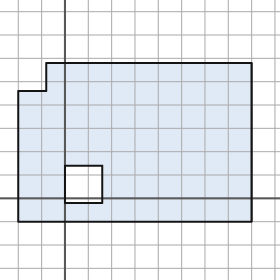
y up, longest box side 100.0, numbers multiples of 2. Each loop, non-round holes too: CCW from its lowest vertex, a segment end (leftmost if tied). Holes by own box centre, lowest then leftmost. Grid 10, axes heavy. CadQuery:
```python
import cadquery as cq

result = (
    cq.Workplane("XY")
    .moveTo(-20.0, -10.0)
    .lineTo(80.0, -10.0)
    .lineTo(80.0, 58.0)
    .lineTo(-8.0, 58.0)
    .lineTo(-8.0, 46.0)
    .lineTo(-20.0, 46.0)
    .close()
    .moveTo(0.0, -2.0)
    .lineTo(16.0, -2.0)
    .lineTo(16.0, 14.0)
    .lineTo(0.0, 14.0)
    .close()
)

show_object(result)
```